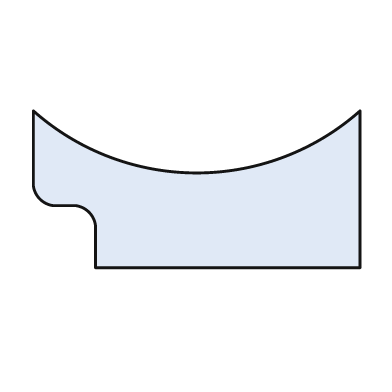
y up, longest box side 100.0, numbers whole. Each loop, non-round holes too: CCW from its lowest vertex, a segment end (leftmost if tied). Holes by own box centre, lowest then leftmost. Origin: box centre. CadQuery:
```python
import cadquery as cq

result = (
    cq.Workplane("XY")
    .moveTo(-31.0, -24.0)
    .lineTo(50.0, -24.0)
    .lineTo(50.0, 24.0)
    .threePointArc((0.0, 5.0), (-50.0, 24.0))
    .lineTo(-50.0, 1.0)
    .threePointArc((-48.0, -3.0), (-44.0, -5.0))
    .lineTo(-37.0, -5.0)
    .threePointArc((-33.0, -7.0), (-31.0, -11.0))
    .close()
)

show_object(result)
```